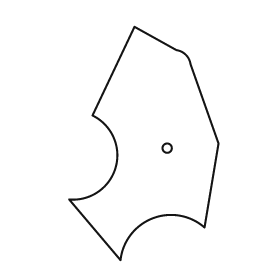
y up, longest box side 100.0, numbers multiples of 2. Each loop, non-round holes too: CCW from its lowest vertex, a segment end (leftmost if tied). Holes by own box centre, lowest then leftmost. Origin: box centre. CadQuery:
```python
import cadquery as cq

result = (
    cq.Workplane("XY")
    .moveTo(-10.0, -50.0)
    .threePointArc((4.0, -32.0), (26.0, -36.0))
    .lineTo(32.0, 0.0)
    .lineTo(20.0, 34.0)
    .threePointArc((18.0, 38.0), (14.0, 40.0))
    .lineTo(-4.0, 50.0)
    .lineTo(-22.0, 12.0)
    .threePointArc((-12.0, -10.0), (-32.0, -24.0))
    .close()
    .moveTo(10.0, -2.0)
    .circle(2.0)
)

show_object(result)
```